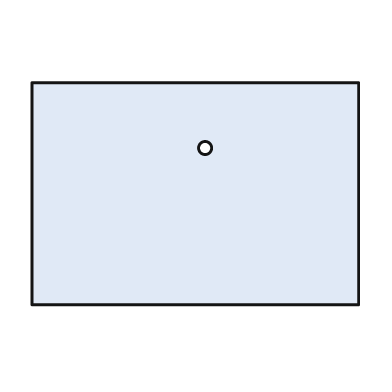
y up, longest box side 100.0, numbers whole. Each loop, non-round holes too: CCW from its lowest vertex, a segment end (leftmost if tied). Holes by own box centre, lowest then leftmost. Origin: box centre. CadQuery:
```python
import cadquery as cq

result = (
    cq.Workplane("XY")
    .moveTo(-50.0, -34.0)
    .lineTo(50.0, -34.0)
    .lineTo(50.0, 34.0)
    .lineTo(-50.0, 34.0)
    .close()
    .moveTo(3.0, 14.0)
    .circle(2.0)
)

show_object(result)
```